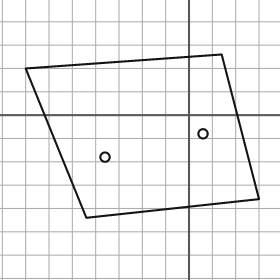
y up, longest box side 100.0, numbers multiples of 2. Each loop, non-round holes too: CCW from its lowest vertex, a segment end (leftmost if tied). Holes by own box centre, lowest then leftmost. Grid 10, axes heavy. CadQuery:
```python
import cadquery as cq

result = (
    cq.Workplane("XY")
    .moveTo(-44.0, -44.0)
    .lineTo(30.0, -36.0)
    .lineTo(14.0, 26.0)
    .lineTo(-70.0, 20.0)
    .close()
    .moveTo(-36.0, -18.0)
    .circle(2.0)
    .moveTo(6.0, -8.0)
    .circle(2.0)
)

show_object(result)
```